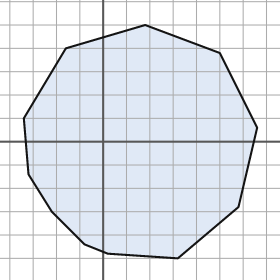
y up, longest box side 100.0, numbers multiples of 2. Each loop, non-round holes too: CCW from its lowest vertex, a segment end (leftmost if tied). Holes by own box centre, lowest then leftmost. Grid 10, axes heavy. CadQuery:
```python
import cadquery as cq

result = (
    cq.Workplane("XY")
    .moveTo(32.0, -50.0)
    .lineTo(58.0, -28.0)
    .lineTo(66.0, 6.0)
    .lineTo(50.0, 38.0)
    .lineTo(18.0, 50.0)
    .lineTo(-16.0, 40.0)
    .lineTo(-34.0, 10.0)
    .lineTo(-32.0, -14.0)
    .lineTo(-22.0, -30.0)
    .lineTo(-8.0, -44.0)
    .lineTo(2.0, -48.0)
    .close()
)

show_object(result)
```